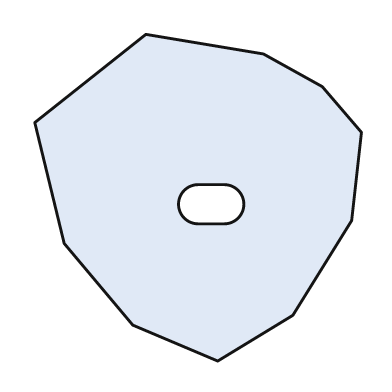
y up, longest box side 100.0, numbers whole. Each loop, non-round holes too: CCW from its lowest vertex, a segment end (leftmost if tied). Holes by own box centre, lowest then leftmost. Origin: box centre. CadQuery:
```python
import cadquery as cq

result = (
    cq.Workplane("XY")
    .moveTo(6.0, -50.0)
    .lineTo(29.0, -36.0)
    .lineTo(47.0, -7.0)
    .lineTo(50.0, 20.0)
    .lineTo(38.0, 34.0)
    .lineTo(20.0, 44.0)
    .lineTo(-16.0, 50.0)
    .lineTo(-50.0, 23.0)
    .lineTo(-41.0, -14.0)
    .lineTo(-20.0, -39.0)
    .close()
    .moveTo(0.0, -8.0)
    .lineTo(8.0, -8.0)
    .threePointArc((14.0, -2.0), (8.0, 4.0))
    .lineTo(0.0, 4.0)
    .threePointArc((-6.0, -2.0), (0.0, -8.0))
    .close()
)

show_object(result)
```